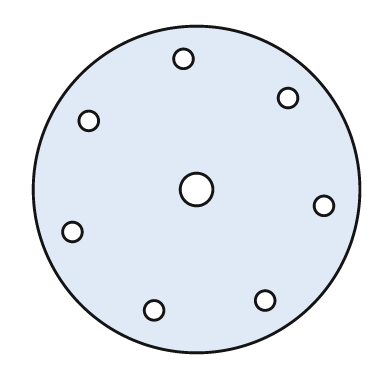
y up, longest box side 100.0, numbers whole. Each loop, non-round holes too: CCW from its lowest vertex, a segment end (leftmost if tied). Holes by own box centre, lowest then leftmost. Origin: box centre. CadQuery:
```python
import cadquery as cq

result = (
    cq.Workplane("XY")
    .moveTo(0.0, 0.0)
    .circle(50.0)
    .moveTo(-13.0, -37.0)
    .circle(3.0)
    .moveTo(21.0, -34.0)
    .circle(3.0)
    .moveTo(-38.0, -13.0)
    .circle(3.0)
    .moveTo(39.0, -5.0)
    .circle(3.0)
    .moveTo(0.0, 0.0)
    .circle(5.0)
    .moveTo(-33.0, 21.0)
    .circle(3.0)
    .moveTo(28.0, 28.0)
    .circle(3.0)
    .moveTo(-4.0, 40.0)
    .circle(3.0)
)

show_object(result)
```